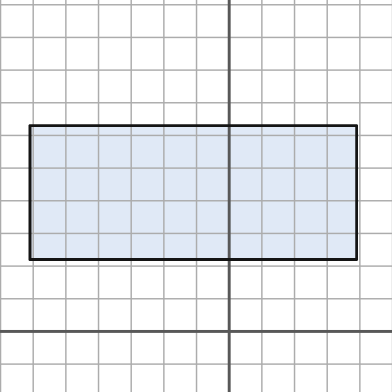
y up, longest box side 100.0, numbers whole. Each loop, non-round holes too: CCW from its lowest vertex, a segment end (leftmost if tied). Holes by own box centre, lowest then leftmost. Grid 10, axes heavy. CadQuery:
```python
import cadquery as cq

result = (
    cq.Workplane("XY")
    .moveTo(-61.0, 22.0)
    .lineTo(39.0, 22.0)
    .lineTo(39.0, 63.0)
    .lineTo(-61.0, 63.0)
    .close()
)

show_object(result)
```